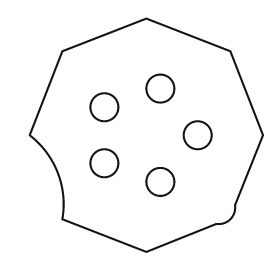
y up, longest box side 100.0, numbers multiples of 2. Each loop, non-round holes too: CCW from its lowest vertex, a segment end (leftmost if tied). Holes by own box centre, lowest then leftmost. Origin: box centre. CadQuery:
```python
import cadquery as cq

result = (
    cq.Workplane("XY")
    .moveTo(0.0, -50.0)
    .lineTo(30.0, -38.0)
    .threePointArc((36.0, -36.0), (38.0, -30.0))
    .lineTo(50.0, 0.0)
    .lineTo(36.0, 36.0)
    .lineTo(0.0, 50.0)
    .lineTo(-36.0, 36.0)
    .lineTo(-50.0, 0.0)
    .threePointArc((-38.0, -16.0), (-36.0, -36.0))
    .close()
    .moveTo(6.0, -20.0)
    .circle(6.0)
    .moveTo(-18.0, -12.0)
    .circle(6.0)
    .moveTo(22.0, 0.0)
    .circle(6.0)
    .moveTo(-18.0, 12.0)
    .circle(6.0)
    .moveTo(6.0, 20.0)
    .circle(6.0)
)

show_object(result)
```